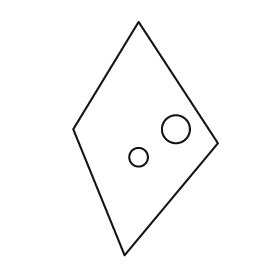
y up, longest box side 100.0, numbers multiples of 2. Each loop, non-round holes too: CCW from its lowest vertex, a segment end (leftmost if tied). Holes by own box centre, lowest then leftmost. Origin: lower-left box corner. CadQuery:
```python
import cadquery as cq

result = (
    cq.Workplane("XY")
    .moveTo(22.0, 0.0)
    .lineTo(62.0, 48.0)
    .lineTo(28.0, 100.0)
    .lineTo(0.0, 54.0)
    .close()
    .moveTo(28.0, 42.0)
    .circle(4.0)
    .moveTo(44.0, 54.0)
    .circle(6.0)
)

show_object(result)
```